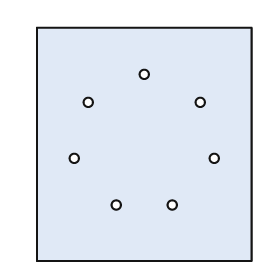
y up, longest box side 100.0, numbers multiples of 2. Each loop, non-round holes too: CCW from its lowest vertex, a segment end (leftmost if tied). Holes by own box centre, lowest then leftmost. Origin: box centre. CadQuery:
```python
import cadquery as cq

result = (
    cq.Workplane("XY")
    .moveTo(-46.0, -50.0)
    .lineTo(46.0, -50.0)
    .lineTo(46.0, 50.0)
    .lineTo(-46.0, 50.0)
    .close()
    .moveTo(-12.0, -26.0)
    .circle(2.0)
    .moveTo(12.0, -26.0)
    .circle(2.0)
    .moveTo(-30.0, -6.0)
    .circle(2.0)
    .moveTo(30.0, -6.0)
    .circle(2.0)
    .moveTo(-24.0, 18.0)
    .circle(2.0)
    .moveTo(24.0, 18.0)
    .circle(2.0)
    .moveTo(0.0, 30.0)
    .circle(2.0)
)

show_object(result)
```